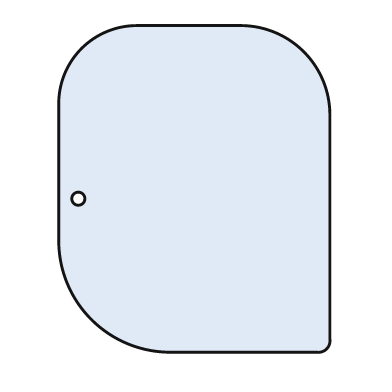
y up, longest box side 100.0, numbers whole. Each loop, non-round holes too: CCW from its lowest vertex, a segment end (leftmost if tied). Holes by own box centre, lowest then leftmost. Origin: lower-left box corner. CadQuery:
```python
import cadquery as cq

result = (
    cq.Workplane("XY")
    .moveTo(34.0, 0.0)
    .lineTo(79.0, 0.0)
    .threePointArc((82.0, 1.0), (83.0, 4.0))
    .lineTo(83.0, 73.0)
    .threePointArc((75.0, 92.0), (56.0, 100.0))
    .lineTo(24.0, 100.0)
    .threePointArc((7.0, 93.0), (0.0, 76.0))
    .lineTo(0.0, 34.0)
    .threePointArc((10.0, 10.0), (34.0, 0.0))
    .close()
    .moveTo(6.0, 47.0)
    .circle(2.0)
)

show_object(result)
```